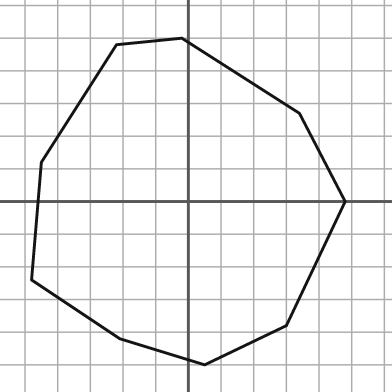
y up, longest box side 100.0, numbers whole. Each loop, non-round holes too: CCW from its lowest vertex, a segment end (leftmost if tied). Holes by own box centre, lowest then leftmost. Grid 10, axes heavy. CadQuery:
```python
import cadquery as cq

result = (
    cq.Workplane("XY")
    .moveTo(5.0, -50.0)
    .lineTo(30.0, -38.0)
    .lineTo(48.0, 0.0)
    .lineTo(34.0, 27.0)
    .lineTo(-2.0, 50.0)
    .lineTo(-22.0, 48.0)
    .lineTo(-45.0, 12.0)
    .lineTo(-48.0, -24.0)
    .lineTo(-21.0, -42.0)
    .close()
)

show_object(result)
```